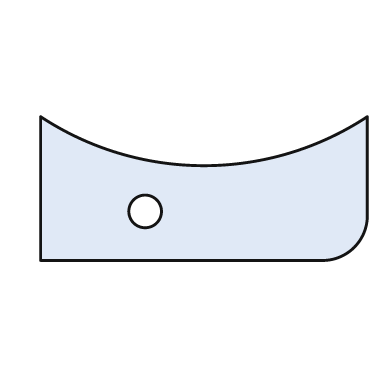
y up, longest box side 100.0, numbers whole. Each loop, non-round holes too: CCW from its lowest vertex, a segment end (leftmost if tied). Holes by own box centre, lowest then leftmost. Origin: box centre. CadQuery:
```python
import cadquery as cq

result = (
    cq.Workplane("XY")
    .moveTo(-50.0, -22.0)
    .lineTo(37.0, -22.0)
    .threePointArc((46.0, -18.0), (50.0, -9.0))
    .lineTo(50.0, 22.0)
    .threePointArc((0.0, 7.0), (-50.0, 22.0))
    .close()
    .moveTo(-18.0, -7.0)
    .circle(5.0)
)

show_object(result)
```